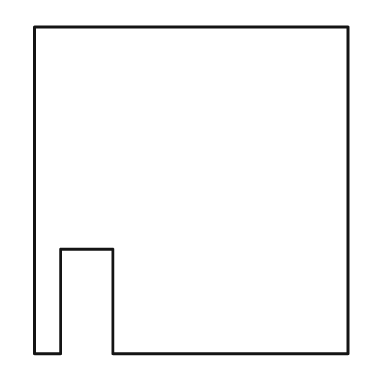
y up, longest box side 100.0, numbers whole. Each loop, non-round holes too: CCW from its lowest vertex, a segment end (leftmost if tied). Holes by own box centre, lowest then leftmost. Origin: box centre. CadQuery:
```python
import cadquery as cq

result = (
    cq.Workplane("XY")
    .moveTo(-48.0, -50.0)
    .lineTo(-40.0, -50.0)
    .lineTo(-40.0, -18.0)
    .lineTo(-24.0, -18.0)
    .lineTo(-24.0, -50.0)
    .lineTo(48.0, -50.0)
    .lineTo(48.0, 50.0)
    .lineTo(-48.0, 50.0)
    .close()
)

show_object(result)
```